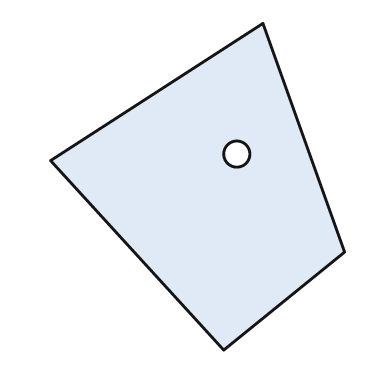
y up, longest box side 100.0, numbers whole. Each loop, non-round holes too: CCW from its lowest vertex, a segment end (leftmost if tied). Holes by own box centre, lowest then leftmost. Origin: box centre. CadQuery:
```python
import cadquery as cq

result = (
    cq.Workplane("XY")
    .moveTo(8.0, -50.0)
    .lineTo(45.0, -20.0)
    .lineTo(20.0, 50.0)
    .lineTo(-45.0, 8.0)
    .close()
    .moveTo(12.0, 10.0)
    .circle(4.0)
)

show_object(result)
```